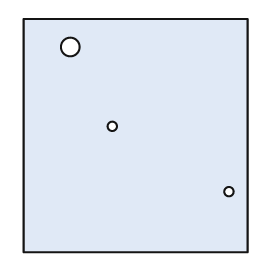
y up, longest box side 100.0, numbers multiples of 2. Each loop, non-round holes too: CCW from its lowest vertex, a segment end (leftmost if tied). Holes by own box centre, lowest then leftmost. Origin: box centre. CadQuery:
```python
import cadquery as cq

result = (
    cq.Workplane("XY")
    .moveTo(-48.0, -50.0)
    .lineTo(48.0, -50.0)
    .lineTo(48.0, 50.0)
    .lineTo(-48.0, 50.0)
    .close()
    .moveTo(40.0, -24.0)
    .circle(2.0)
    .moveTo(-10.0, 4.0)
    .circle(2.0)
    .moveTo(-28.0, 38.0)
    .circle(4.0)
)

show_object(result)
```